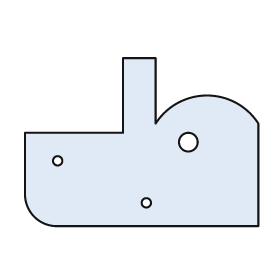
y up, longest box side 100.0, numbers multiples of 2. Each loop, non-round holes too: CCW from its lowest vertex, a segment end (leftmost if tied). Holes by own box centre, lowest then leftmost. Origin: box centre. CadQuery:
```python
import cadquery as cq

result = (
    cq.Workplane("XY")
    .moveTo(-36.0, -36.0)
    .lineTo(50.0, -36.0)
    .lineTo(50.0, 8.0)
    .threePointArc((28.0, 20.0), (6.0, 8.0))
    .lineTo(6.0, 36.0)
    .lineTo(-8.0, 36.0)
    .lineTo(-8.0, 4.0)
    .lineTo(-50.0, 4.0)
    .lineTo(-50.0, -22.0)
    .threePointArc((-46.0, -32.0), (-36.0, -36.0))
    .close()
    .moveTo(2.0, -26.0)
    .circle(2.0)
    .moveTo(-36.0, -8.0)
    .circle(2.0)
    .moveTo(20.0, 0.0)
    .circle(4.0)
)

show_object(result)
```